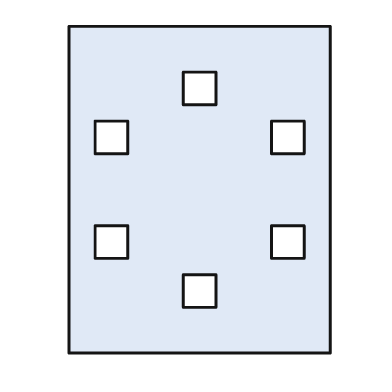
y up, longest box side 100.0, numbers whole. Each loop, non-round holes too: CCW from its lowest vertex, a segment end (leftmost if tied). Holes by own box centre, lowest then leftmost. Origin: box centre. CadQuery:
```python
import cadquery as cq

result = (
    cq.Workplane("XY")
    .moveTo(-40.0, -50.0)
    .lineTo(40.0, -50.0)
    .lineTo(40.0, 50.0)
    .lineTo(-40.0, 50.0)
    .close()
    .moveTo(-5.0, -36.0)
    .lineTo(5.0, -36.0)
    .lineTo(5.0, -26.0)
    .lineTo(-5.0, -26.0)
    .close()
    .moveTo(-32.0, -21.0)
    .lineTo(-22.0, -21.0)
    .lineTo(-22.0, -11.0)
    .lineTo(-32.0, -11.0)
    .close()
    .moveTo(22.0, -21.0)
    .lineTo(32.0, -21.0)
    .lineTo(32.0, -11.0)
    .lineTo(22.0, -11.0)
    .close()
    .moveTo(-32.0, 11.0)
    .lineTo(-22.0, 11.0)
    .lineTo(-22.0, 21.0)
    .lineTo(-32.0, 21.0)
    .close()
    .moveTo(22.0, 11.0)
    .lineTo(32.0, 11.0)
    .lineTo(32.0, 21.0)
    .lineTo(22.0, 21.0)
    .close()
    .moveTo(-5.0, 26.0)
    .lineTo(5.0, 26.0)
    .lineTo(5.0, 36.0)
    .lineTo(-5.0, 36.0)
    .close()
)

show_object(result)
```